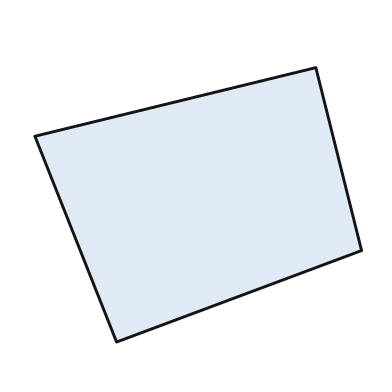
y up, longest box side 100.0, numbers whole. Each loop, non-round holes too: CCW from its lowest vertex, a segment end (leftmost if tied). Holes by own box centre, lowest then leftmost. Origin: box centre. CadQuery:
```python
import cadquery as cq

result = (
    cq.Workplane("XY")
    .moveTo(-25.0, -42.0)
    .lineTo(50.0, -14.0)
    .lineTo(36.0, 42.0)
    .lineTo(-50.0, 21.0)
    .close()
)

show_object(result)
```